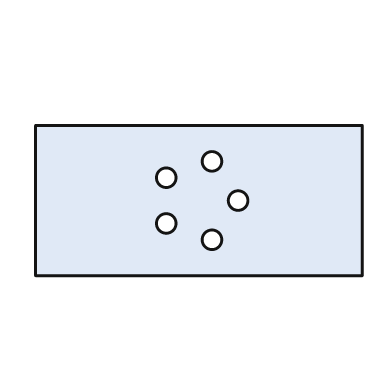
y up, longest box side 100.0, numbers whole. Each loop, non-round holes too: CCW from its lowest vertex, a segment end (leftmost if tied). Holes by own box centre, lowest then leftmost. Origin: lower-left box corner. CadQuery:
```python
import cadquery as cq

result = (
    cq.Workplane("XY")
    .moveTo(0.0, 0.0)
    .lineTo(100.0, 0.0)
    .lineTo(100.0, 46.0)
    .lineTo(0.0, 46.0)
    .close()
    .moveTo(54.0, 11.0)
    .circle(3.0)
    .moveTo(40.0, 16.0)
    .circle(3.0)
    .moveTo(62.0, 23.0)
    .circle(3.0)
    .moveTo(40.0, 30.0)
    .circle(3.0)
    .moveTo(54.0, 35.0)
    .circle(3.0)
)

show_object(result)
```